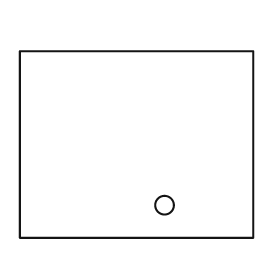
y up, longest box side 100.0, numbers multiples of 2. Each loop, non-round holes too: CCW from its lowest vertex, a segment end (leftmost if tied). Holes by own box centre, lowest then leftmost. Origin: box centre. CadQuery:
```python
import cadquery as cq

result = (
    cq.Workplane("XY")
    .moveTo(-50.0, -40.0)
    .lineTo(50.0, -40.0)
    .lineTo(50.0, 40.0)
    .lineTo(-50.0, 40.0)
    .close()
    .moveTo(12.0, -26.0)
    .circle(4.0)
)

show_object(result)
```